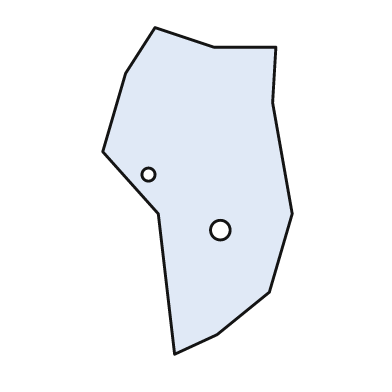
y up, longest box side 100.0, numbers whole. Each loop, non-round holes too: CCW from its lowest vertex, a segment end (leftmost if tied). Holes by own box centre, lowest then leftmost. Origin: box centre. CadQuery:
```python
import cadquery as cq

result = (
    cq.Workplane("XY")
    .moveTo(-7.0, -50.0)
    .lineTo(6.0, -44.0)
    .lineTo(22.0, -31.0)
    .lineTo(29.0, -7.0)
    .lineTo(23.0, 27.0)
    .lineTo(24.0, 44.0)
    .lineTo(5.0, 44.0)
    .lineTo(-13.0, 50.0)
    .lineTo(-22.0, 36.0)
    .lineTo(-29.0, 12.0)
    .lineTo(-12.0, -7.0)
    .close()
    .moveTo(7.0, -12.0)
    .circle(3.0)
    .moveTo(-15.0, 5.0)
    .circle(2.0)
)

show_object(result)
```